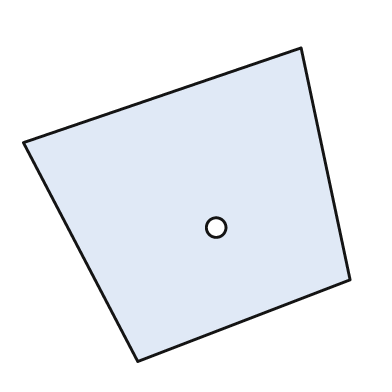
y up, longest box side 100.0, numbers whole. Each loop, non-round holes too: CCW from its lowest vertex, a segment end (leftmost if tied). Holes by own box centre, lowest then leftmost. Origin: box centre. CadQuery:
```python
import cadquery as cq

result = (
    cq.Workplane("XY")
    .moveTo(-15.0, -48.0)
    .lineTo(50.0, -23.0)
    .lineTo(35.0, 48.0)
    .lineTo(-50.0, 19.0)
    .close()
    .moveTo(9.0, -7.0)
    .circle(3.0)
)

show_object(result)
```